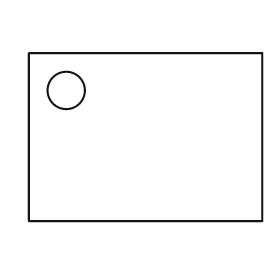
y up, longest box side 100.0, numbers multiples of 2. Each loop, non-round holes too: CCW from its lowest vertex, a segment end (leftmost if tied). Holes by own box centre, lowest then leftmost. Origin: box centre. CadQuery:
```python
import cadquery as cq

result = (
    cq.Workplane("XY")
    .moveTo(-50.0, -36.0)
    .lineTo(50.0, -36.0)
    .lineTo(50.0, 36.0)
    .lineTo(-50.0, 36.0)
    .close()
    .moveTo(-34.0, 20.0)
    .circle(8.0)
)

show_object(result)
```